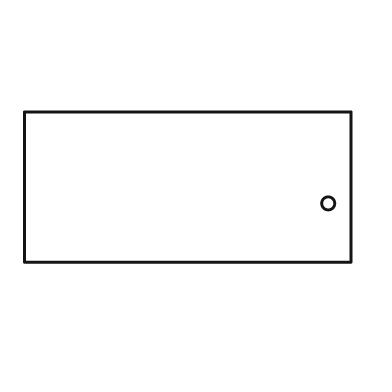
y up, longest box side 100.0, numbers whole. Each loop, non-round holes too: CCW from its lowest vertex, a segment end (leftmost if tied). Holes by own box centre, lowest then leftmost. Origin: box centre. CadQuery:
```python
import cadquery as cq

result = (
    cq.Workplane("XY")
    .moveTo(-50.0, -23.0)
    .lineTo(50.0, -23.0)
    .lineTo(50.0, 23.0)
    .lineTo(-50.0, 23.0)
    .close()
    .moveTo(43.0, -5.0)
    .circle(2.0)
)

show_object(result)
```